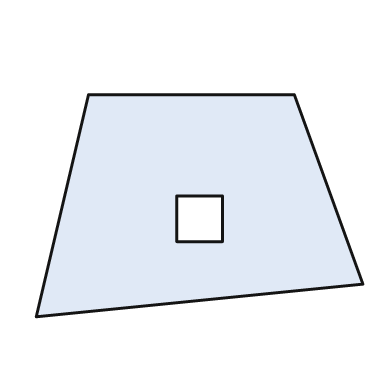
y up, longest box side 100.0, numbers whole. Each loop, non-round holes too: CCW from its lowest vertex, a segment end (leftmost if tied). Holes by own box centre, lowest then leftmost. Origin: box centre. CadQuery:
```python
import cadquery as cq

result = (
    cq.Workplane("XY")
    .moveTo(-50.0, -34.0)
    .lineTo(50.0, -24.0)
    .lineTo(29.0, 34.0)
    .lineTo(-34.0, 34.0)
    .close()
    .moveTo(-7.0, -11.0)
    .lineTo(7.0, -11.0)
    .lineTo(7.0, 3.0)
    .lineTo(-7.0, 3.0)
    .close()
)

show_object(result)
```